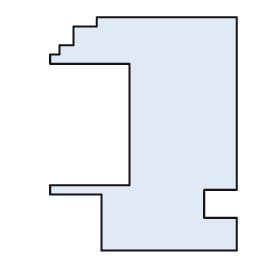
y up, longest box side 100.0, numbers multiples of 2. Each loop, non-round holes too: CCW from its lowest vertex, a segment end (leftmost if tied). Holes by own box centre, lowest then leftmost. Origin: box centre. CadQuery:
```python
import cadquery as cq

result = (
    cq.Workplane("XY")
    .moveTo(-18.0, -50.0)
    .lineTo(40.0, -50.0)
    .lineTo(40.0, -36.0)
    .lineTo(26.0, -36.0)
    .lineTo(26.0, -24.0)
    .lineTo(40.0, -24.0)
    .lineTo(40.0, 50.0)
    .lineTo(-20.0, 50.0)
    .lineTo(-20.0, 46.0)
    .lineTo(-30.0, 46.0)
    .lineTo(-30.0, 38.0)
    .lineTo(-36.0, 38.0)
    .lineTo(-36.0, 34.0)
    .lineTo(-40.0, 34.0)
    .lineTo(-40.0, 30.0)
    .lineTo(-6.0, 30.0)
    .lineTo(-6.0, -22.0)
    .lineTo(-40.0, -22.0)
    .lineTo(-40.0, -26.0)
    .lineTo(-18.0, -26.0)
    .close()
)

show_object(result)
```